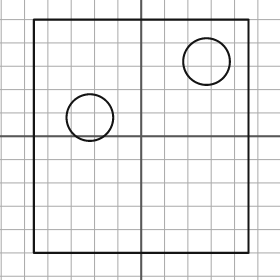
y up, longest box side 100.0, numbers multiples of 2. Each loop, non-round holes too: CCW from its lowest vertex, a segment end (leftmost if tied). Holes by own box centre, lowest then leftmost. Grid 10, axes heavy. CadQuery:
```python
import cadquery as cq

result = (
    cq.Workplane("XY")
    .moveTo(-46.0, -50.0)
    .lineTo(46.0, -50.0)
    .lineTo(46.0, 50.0)
    .lineTo(-46.0, 50.0)
    .close()
    .moveTo(-22.0, 8.0)
    .circle(10.0)
    .moveTo(28.0, 32.0)
    .circle(10.0)
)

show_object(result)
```